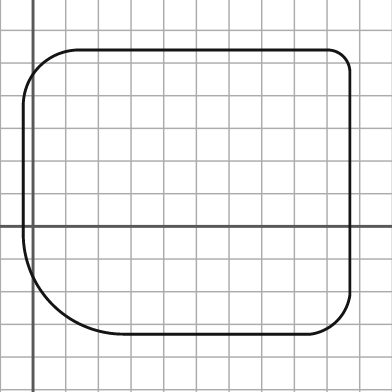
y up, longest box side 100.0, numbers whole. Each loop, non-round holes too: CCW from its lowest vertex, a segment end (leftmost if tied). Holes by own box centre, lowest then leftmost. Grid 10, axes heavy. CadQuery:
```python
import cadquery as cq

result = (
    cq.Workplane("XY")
    .moveTo(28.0, -33.0)
    .lineTo(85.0, -33.0)
    .threePointArc((93.0, -29.0), (97.0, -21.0))
    .lineTo(97.0, 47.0)
    .threePointArc((95.0, 52.0), (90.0, 54.0))
    .lineTo(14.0, 54.0)
    .threePointArc((2.0, 49.0), (-3.0, 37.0))
    .lineTo(-3.0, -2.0)
    .threePointArc((6.0, -24.0), (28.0, -33.0))
    .close()
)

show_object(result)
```